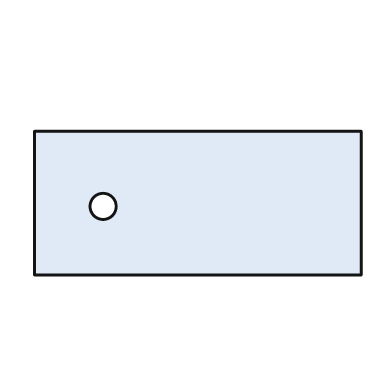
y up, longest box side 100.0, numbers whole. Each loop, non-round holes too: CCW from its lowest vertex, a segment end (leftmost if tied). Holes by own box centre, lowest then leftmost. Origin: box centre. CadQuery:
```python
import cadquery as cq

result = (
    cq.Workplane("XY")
    .moveTo(-50.0, -22.0)
    .lineTo(50.0, -22.0)
    .lineTo(50.0, 22.0)
    .lineTo(-50.0, 22.0)
    .close()
    .moveTo(-29.0, -1.0)
    .circle(4.0)
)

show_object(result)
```